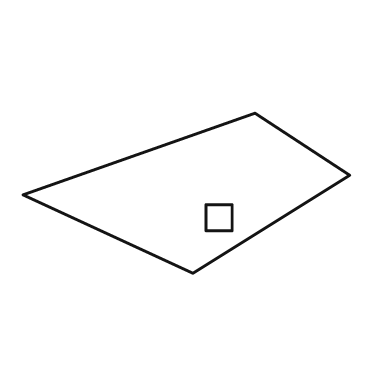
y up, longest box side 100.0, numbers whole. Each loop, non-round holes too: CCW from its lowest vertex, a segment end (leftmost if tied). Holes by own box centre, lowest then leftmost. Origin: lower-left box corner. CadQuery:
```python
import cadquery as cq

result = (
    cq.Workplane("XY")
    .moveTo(52.0, 0.0)
    .lineTo(100.0, 30.0)
    .lineTo(71.0, 49.0)
    .lineTo(0.0, 24.0)
    .close()
    .moveTo(56.0, 13.0)
    .lineTo(64.0, 13.0)
    .lineTo(64.0, 21.0)
    .lineTo(56.0, 21.0)
    .close()
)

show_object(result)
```